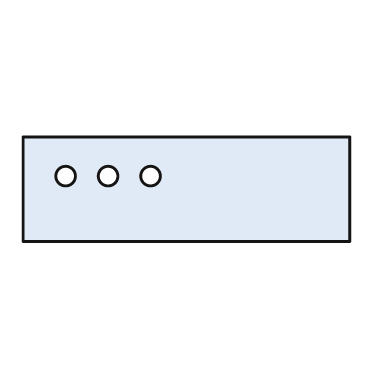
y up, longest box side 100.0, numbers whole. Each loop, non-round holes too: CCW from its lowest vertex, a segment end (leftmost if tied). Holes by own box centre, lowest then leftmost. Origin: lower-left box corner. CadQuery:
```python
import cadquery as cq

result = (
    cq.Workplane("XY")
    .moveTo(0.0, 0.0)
    .lineTo(100.0, 0.0)
    .lineTo(100.0, 32.0)
    .lineTo(0.0, 32.0)
    .close()
    .moveTo(13.0, 20.0)
    .circle(3.0)
    .moveTo(26.0, 20.0)
    .circle(3.0)
    .moveTo(39.0, 20.0)
    .circle(3.0)
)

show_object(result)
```